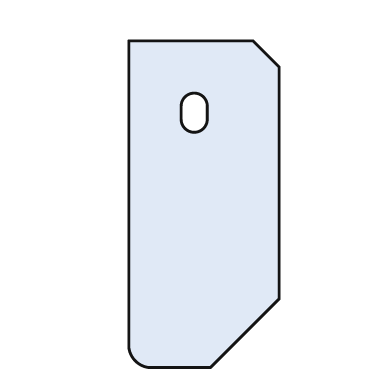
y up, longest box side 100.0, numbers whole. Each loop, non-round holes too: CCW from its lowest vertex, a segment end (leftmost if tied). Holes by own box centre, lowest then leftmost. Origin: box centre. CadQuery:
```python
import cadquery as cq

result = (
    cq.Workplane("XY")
    .moveTo(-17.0, -50.0)
    .lineTo(2.0, -50.0)
    .lineTo(23.0, -29.0)
    .lineTo(23.0, 42.0)
    .lineTo(15.0, 50.0)
    .lineTo(-23.0, 50.0)
    .lineTo(-23.0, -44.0)
    .threePointArc((-21.0, -48.0), (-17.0, -50.0))
    .close()
    .moveTo(-7.0, 26.0)
    .threePointArc((-3.0, 22.0), (1.0, 26.0))
    .lineTo(1.0, 30.0)
    .threePointArc((-3.0, 34.0), (-7.0, 30.0))
    .close()
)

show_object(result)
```